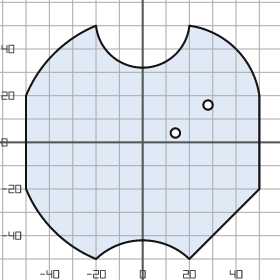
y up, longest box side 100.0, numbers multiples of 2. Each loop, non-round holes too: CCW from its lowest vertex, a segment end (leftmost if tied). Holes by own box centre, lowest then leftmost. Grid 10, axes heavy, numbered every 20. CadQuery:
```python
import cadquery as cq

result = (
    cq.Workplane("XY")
    .moveTo(-20.0, -50.0)
    .threePointArc((0.0, -42.0), (20.0, -50.0))
    .lineTo(50.0, -20.0)
    .lineTo(50.0, 20.0)
    .threePointArc((40.0, 40.0), (20.0, 50.0))
    .threePointArc((0.0, 32.0), (-20.0, 50.0))
    .threePointArc((-38.0, 38.0), (-50.0, 20.0))
    .lineTo(-50.0, -20.0)
    .threePointArc((-38.0, -38.0), (-20.0, -50.0))
    .close()
    .moveTo(14.0, 4.0)
    .circle(2.0)
    .moveTo(28.0, 16.0)
    .circle(2.0)
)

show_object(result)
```